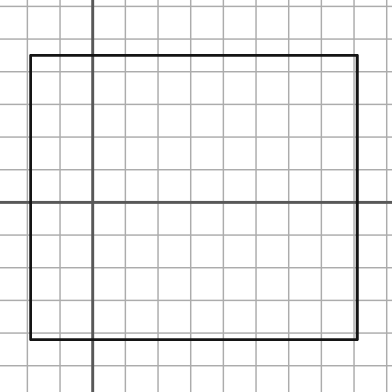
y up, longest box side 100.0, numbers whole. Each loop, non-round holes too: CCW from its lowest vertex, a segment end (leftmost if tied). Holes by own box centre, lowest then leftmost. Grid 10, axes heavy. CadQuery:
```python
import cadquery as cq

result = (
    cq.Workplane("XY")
    .moveTo(-19.0, -42.0)
    .lineTo(81.0, -42.0)
    .lineTo(81.0, 45.0)
    .lineTo(-19.0, 45.0)
    .close()
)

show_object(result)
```